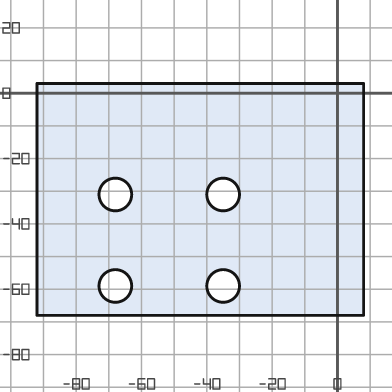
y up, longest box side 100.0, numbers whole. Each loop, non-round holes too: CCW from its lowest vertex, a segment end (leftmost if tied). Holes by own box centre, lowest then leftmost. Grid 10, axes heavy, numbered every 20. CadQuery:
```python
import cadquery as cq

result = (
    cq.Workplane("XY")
    .moveTo(-92.0, -68.0)
    .lineTo(8.0, -68.0)
    .lineTo(8.0, 3.0)
    .lineTo(-92.0, 3.0)
    .close()
    .moveTo(-68.0, -59.0)
    .circle(5.0)
    .moveTo(-35.0, -59.0)
    .circle(5.0)
    .moveTo(-68.0, -31.0)
    .circle(5.0)
    .moveTo(-35.0, -31.0)
    .circle(5.0)
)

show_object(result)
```